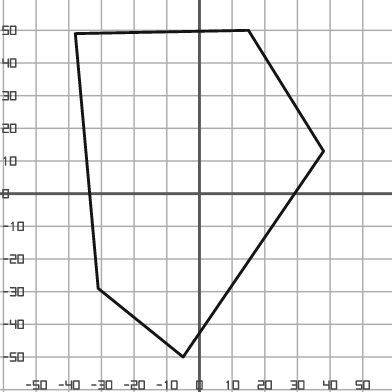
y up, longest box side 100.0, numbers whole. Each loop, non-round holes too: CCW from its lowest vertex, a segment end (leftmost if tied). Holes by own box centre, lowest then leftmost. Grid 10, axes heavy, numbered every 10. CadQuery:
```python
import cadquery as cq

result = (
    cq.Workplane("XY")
    .moveTo(-5.0, -50.0)
    .lineTo(38.0, 13.0)
    .lineTo(15.0, 50.0)
    .lineTo(-38.0, 49.0)
    .lineTo(-31.0, -29.0)
    .close()
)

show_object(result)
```